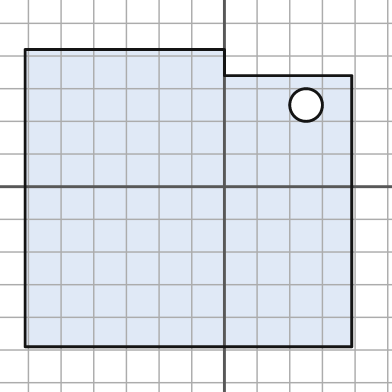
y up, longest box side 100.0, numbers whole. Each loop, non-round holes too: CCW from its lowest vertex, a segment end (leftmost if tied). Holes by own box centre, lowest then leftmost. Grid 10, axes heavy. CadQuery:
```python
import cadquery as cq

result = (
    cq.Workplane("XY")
    .moveTo(-61.0, -49.0)
    .lineTo(39.0, -49.0)
    .lineTo(39.0, 34.0)
    .lineTo(0.0, 34.0)
    .lineTo(0.0, 42.0)
    .lineTo(-61.0, 42.0)
    .close()
    .moveTo(25.0, 25.0)
    .circle(5.0)
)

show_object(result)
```